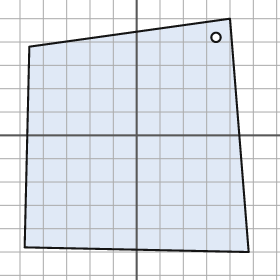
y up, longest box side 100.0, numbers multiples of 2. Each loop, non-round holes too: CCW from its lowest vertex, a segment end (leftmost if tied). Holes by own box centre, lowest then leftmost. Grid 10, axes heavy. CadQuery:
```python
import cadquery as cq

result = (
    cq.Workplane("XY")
    .moveTo(48.0, -50.0)
    .lineTo(40.0, 50.0)
    .lineTo(-46.0, 38.0)
    .lineTo(-48.0, -48.0)
    .close()
    .moveTo(34.0, 42.0)
    .circle(2.0)
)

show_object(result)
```